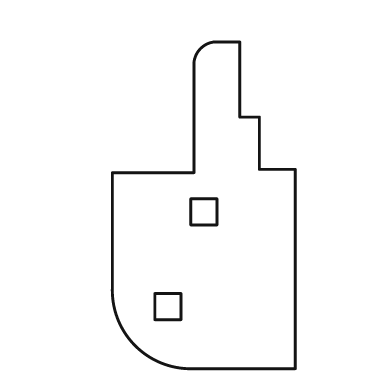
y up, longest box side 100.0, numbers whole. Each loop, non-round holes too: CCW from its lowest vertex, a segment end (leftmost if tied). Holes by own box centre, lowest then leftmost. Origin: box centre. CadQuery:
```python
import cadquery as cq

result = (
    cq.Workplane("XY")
    .moveTo(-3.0, -50.0)
    .lineTo(28.0, -50.0)
    .lineTo(28.0, 11.0)
    .lineTo(17.0, 11.0)
    .lineTo(17.0, 27.0)
    .lineTo(11.0, 27.0)
    .lineTo(11.0, 50.0)
    .lineTo(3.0, 50.0)
    .threePointArc((-1.0, 48.0), (-3.0, 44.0))
    .lineTo(-3.0, 10.0)
    .lineTo(-28.0, 10.0)
    .lineTo(-28.0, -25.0)
    .threePointArc((-21.0, -43.0), (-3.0, -50.0))
    .close()
    .moveTo(-15.0, -35.0)
    .lineTo(-7.0, -35.0)
    .lineTo(-7.0, -27.0)
    .lineTo(-15.0, -27.0)
    .close()
    .moveTo(-4.0, -6.0)
    .lineTo(4.0, -6.0)
    .lineTo(4.0, 2.0)
    .lineTo(-4.0, 2.0)
    .close()
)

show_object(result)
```